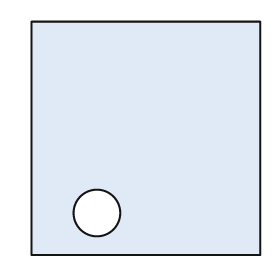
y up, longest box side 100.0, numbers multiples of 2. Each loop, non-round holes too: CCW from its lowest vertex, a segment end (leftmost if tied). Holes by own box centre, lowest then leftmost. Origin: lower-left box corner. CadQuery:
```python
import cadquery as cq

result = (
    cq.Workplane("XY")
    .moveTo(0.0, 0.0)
    .lineTo(98.0, 0.0)
    .lineTo(98.0, 100.0)
    .lineTo(0.0, 100.0)
    .close()
    .moveTo(28.0, 18.0)
    .circle(10.0)
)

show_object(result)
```